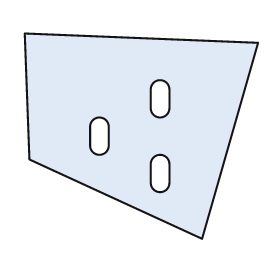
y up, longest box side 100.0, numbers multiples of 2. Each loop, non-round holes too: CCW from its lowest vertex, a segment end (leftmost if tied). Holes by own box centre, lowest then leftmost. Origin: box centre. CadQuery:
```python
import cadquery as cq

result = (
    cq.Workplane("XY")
    .moveTo(26.0, -44.0)
    .lineTo(50.0, 40.0)
    .lineTo(-50.0, 44.0)
    .lineTo(-48.0, -10.0)
    .close()
    .moveTo(4.0, -20.0)
    .threePointArc((8.0, -24.0), (12.0, -20.0))
    .lineTo(12.0, -12.0)
    .threePointArc((8.0, -8.0), (4.0, -12.0))
    .close()
    .moveTo(-22.0, -4.0)
    .threePointArc((-18.0, -8.0), (-14.0, -4.0))
    .lineTo(-14.0, 4.0)
    .threePointArc((-18.0, 8.0), (-22.0, 4.0))
    .close()
    .moveTo(4.0, 12.0)
    .threePointArc((8.0, 8.0), (12.0, 12.0))
    .lineTo(12.0, 20.0)
    .threePointArc((8.0, 24.0), (4.0, 20.0))
    .close()
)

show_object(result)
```